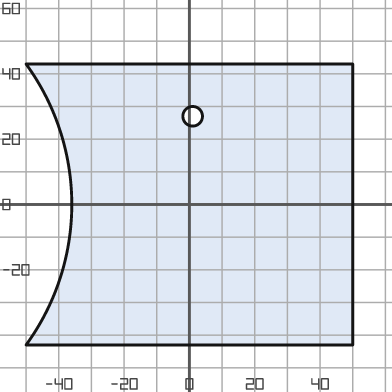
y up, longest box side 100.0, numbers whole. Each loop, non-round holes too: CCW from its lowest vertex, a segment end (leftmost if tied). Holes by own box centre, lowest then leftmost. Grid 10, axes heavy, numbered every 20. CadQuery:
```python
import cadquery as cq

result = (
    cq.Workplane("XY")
    .moveTo(-50.0, -43.0)
    .lineTo(50.0, -43.0)
    .lineTo(50.0, 43.0)
    .lineTo(-50.0, 43.0)
    .threePointArc((-36.0, 0.0), (-50.0, -43.0))
    .close()
    .moveTo(1.0, 27.0)
    .circle(3.0)
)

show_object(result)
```